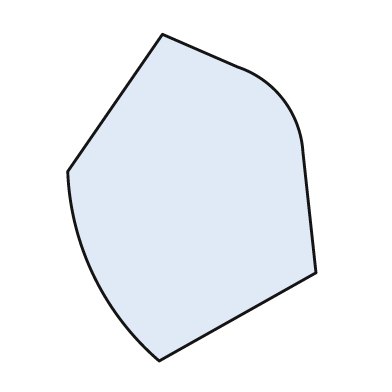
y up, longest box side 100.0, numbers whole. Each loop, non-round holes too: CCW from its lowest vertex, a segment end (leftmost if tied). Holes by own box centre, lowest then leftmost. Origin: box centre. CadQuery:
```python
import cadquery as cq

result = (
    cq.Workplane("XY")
    .moveTo(-10.0, -50.0)
    .lineTo(38.0, -23.0)
    .lineTo(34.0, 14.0)
    .threePointArc((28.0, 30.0), (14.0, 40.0))
    .lineTo(-9.0, 50.0)
    .lineTo(-38.0, 8.0)
    .threePointArc((-30.0, -24.0), (-10.0, -50.0))
    .close()
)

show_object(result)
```